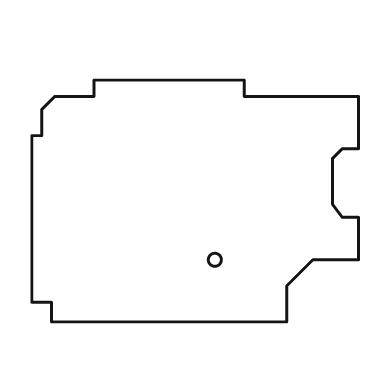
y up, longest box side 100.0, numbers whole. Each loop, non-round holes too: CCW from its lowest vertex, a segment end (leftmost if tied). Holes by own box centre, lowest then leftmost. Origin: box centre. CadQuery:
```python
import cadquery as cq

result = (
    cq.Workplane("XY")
    .moveTo(-44.0, -37.0)
    .lineTo(28.0, -37.0)
    .lineTo(28.0, -26.0)
    .lineTo(36.0, -18.0)
    .lineTo(50.0, -18.0)
    .lineTo(50.0, -5.0)
    .lineTo(45.0, -5.0)
    .lineTo(42.0, -1.0)
    .lineTo(42.0, 13.0)
    .lineTo(45.0, 16.0)
    .lineTo(50.0, 16.0)
    .lineTo(50.0, 32.0)
    .lineTo(15.0, 32.0)
    .lineTo(15.0, 37.0)
    .lineTo(-31.0, 37.0)
    .lineTo(-31.0, 32.0)
    .lineTo(-43.0, 32.0)
    .lineTo(-47.0, 28.0)
    .lineTo(-47.0, 20.0)
    .lineTo(-50.0, 20.0)
    .lineTo(-50.0, -31.0)
    .lineTo(-44.0, -31.0)
    .close()
    .moveTo(6.0, -18.0)
    .circle(2.0)
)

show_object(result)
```